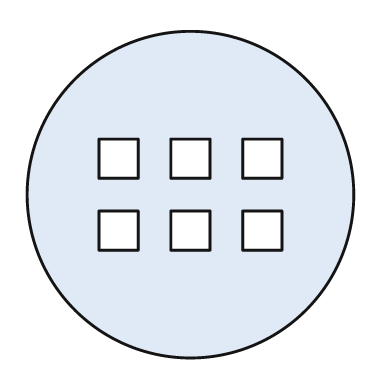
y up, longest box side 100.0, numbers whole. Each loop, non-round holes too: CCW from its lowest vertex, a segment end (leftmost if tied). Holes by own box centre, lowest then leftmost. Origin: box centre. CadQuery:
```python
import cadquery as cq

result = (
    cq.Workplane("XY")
    .moveTo(0.0, 0.0)
    .circle(50.0)
    .moveTo(-28.0, -17.0)
    .lineTo(-16.0, -17.0)
    .lineTo(-16.0, -5.0)
    .lineTo(-28.0, -5.0)
    .close()
    .moveTo(-6.0, -17.0)
    .lineTo(6.0, -17.0)
    .lineTo(6.0, -5.0)
    .lineTo(-6.0, -5.0)
    .close()
    .moveTo(16.0, -17.0)
    .lineTo(28.0, -17.0)
    .lineTo(28.0, -5.0)
    .lineTo(16.0, -5.0)
    .close()
    .moveTo(-28.0, 5.0)
    .lineTo(-16.0, 5.0)
    .lineTo(-16.0, 17.0)
    .lineTo(-28.0, 17.0)
    .close()
    .moveTo(-6.0, 5.0)
    .lineTo(6.0, 5.0)
    .lineTo(6.0, 17.0)
    .lineTo(-6.0, 17.0)
    .close()
    .moveTo(16.0, 5.0)
    .lineTo(28.0, 5.0)
    .lineTo(28.0, 17.0)
    .lineTo(16.0, 17.0)
    .close()
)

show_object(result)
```